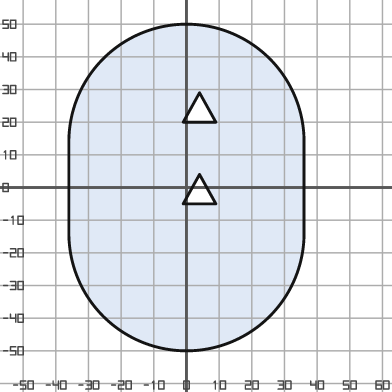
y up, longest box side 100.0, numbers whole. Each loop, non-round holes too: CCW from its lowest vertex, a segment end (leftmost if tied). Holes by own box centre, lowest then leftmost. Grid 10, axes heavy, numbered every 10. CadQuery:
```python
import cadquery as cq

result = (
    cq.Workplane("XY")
    .moveTo(-36.0, -14.0)
    .threePointArc((0.0, -50.0), (36.0, -14.0))
    .lineTo(36.0, 14.0)
    .threePointArc((0.0, 50.0), (-36.0, 14.0))
    .close()
    .moveTo(-1.0, -5.0)
    .lineTo(9.0, -5.0)
    .lineTo(4.0, 4.0)
    .close()
    .moveTo(-1.0, 20.0)
    .lineTo(9.0, 20.0)
    .lineTo(4.0, 29.0)
    .close()
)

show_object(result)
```